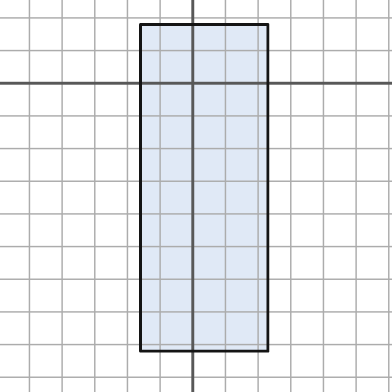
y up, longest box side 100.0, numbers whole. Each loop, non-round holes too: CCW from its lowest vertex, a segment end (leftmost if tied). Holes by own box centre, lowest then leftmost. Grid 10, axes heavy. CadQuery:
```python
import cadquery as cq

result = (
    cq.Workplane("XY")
    .moveTo(-16.0, -82.0)
    .lineTo(23.0, -82.0)
    .lineTo(23.0, 18.0)
    .lineTo(-16.0, 18.0)
    .close()
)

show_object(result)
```